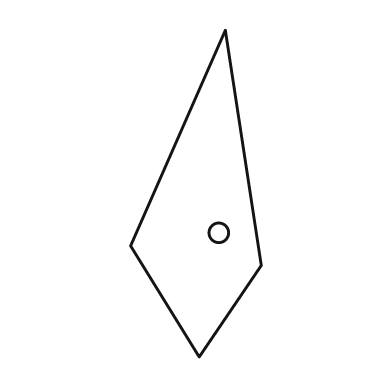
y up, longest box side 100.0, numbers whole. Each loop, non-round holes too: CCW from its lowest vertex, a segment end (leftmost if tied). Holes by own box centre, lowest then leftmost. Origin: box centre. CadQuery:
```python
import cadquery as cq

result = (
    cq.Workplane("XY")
    .moveTo(1.0, -50.0)
    .lineTo(20.0, -22.0)
    .lineTo(9.0, 50.0)
    .lineTo(-20.0, -16.0)
    .close()
    .moveTo(7.0, -12.0)
    .circle(3.0)
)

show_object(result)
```